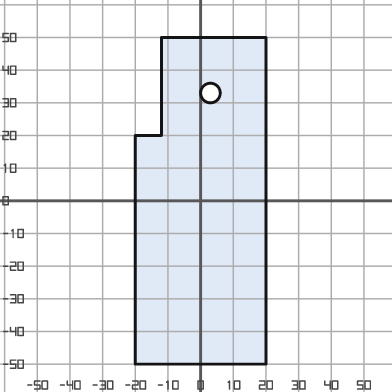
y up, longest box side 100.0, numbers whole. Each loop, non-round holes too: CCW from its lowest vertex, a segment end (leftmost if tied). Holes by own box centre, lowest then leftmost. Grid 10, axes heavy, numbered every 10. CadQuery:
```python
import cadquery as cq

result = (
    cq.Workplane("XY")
    .moveTo(-20.0, -50.0)
    .lineTo(20.0, -50.0)
    .lineTo(20.0, 50.0)
    .lineTo(-12.0, 50.0)
    .lineTo(-12.0, 20.0)
    .lineTo(-20.0, 20.0)
    .close()
    .moveTo(3.0, 33.0)
    .circle(3.0)
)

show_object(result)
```